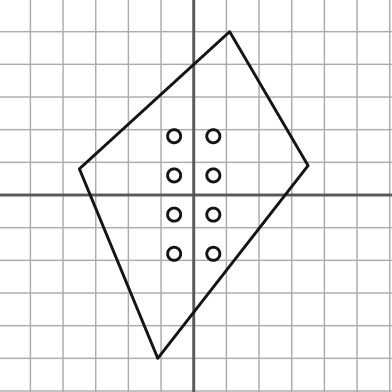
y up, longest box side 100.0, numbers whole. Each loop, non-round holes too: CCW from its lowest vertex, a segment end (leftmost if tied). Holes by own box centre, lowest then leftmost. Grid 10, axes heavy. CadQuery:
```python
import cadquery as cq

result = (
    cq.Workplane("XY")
    .moveTo(-11.0, -50.0)
    .lineTo(35.0, 9.0)
    .lineTo(11.0, 50.0)
    .lineTo(-35.0, 8.0)
    .close()
    .moveTo(-6.0, -18.0)
    .circle(2.0)
    .moveTo(6.0, -18.0)
    .circle(2.0)
    .moveTo(-6.0, -6.0)
    .circle(2.0)
    .moveTo(6.0, -6.0)
    .circle(2.0)
    .moveTo(-6.0, 6.0)
    .circle(2.0)
    .moveTo(6.0, 6.0)
    .circle(2.0)
    .moveTo(-6.0, 18.0)
    .circle(2.0)
    .moveTo(6.0, 18.0)
    .circle(2.0)
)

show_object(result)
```